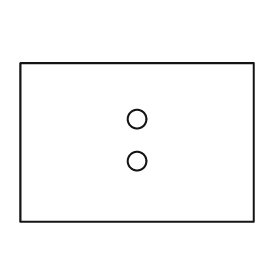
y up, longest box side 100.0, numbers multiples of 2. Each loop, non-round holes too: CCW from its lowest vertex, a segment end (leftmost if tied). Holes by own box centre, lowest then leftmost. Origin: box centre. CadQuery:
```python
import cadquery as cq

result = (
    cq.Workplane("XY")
    .moveTo(-50.0, -34.0)
    .lineTo(50.0, -34.0)
    .lineTo(50.0, 34.0)
    .lineTo(-50.0, 34.0)
    .close()
    .moveTo(0.0, -8.0)
    .circle(4.0)
    .moveTo(0.0, 10.0)
    .circle(4.0)
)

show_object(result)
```